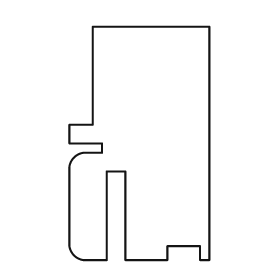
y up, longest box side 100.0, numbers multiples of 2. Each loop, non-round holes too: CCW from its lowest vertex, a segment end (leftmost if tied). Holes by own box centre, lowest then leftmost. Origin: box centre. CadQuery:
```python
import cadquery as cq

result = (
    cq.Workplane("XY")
    .moveTo(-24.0, -50.0)
    .lineTo(-14.0, -50.0)
    .lineTo(-14.0, -12.0)
    .lineTo(-6.0, -12.0)
    .lineTo(-6.0, -50.0)
    .lineTo(12.0, -50.0)
    .lineTo(12.0, -44.0)
    .lineTo(26.0, -44.0)
    .lineTo(26.0, -50.0)
    .lineTo(30.0, -50.0)
    .lineTo(30.0, 50.0)
    .lineTo(-20.0, 50.0)
    .lineTo(-20.0, 8.0)
    .lineTo(-30.0, 8.0)
    .lineTo(-30.0, 0.0)
    .lineTo(-16.0, 0.0)
    .lineTo(-16.0, -4.0)
    .lineTo(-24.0, -4.0)
    .threePointArc((-28.0, -6.0), (-30.0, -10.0))
    .lineTo(-30.0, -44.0)
    .threePointArc((-28.0, -48.0), (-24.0, -50.0))
    .close()
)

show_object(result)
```